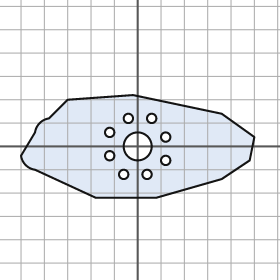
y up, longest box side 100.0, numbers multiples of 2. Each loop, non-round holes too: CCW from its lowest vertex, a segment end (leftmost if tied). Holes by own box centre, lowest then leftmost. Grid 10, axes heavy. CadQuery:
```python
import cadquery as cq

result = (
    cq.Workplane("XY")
    .moveTo(-18.0, -22.0)
    .lineTo(8.0, -22.0)
    .lineTo(36.0, -14.0)
    .lineTo(48.0, -6.0)
    .lineTo(50.0, 4.0)
    .lineTo(36.0, 14.0)
    .lineTo(-2.0, 22.0)
    .lineTo(-30.0, 20.0)
    .lineTo(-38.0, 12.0)
    .threePointArc((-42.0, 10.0), (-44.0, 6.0))
    .lineTo(-50.0, -4.0)
    .threePointArc((-48.0, -8.0), (-44.0, -10.0))
    .close()
    .moveTo(-6.0, -12.0)
    .circle(2.0)
    .moveTo(4.0, -12.0)
    .circle(2.0)
    .moveTo(12.0, -6.0)
    .circle(2.0)
    .moveTo(-12.0, -4.0)
    .circle(2.0)
    .moveTo(0.0, 0.0)
    .circle(6.0)
    .moveTo(12.0, 4.0)
    .circle(2.0)
    .moveTo(-12.0, 6.0)
    .circle(2.0)
    .moveTo(-4.0, 12.0)
    .circle(2.0)
    .moveTo(6.0, 12.0)
    .circle(2.0)
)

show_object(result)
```